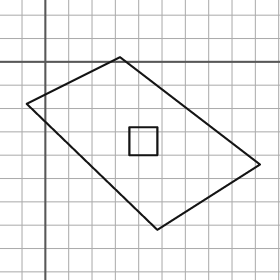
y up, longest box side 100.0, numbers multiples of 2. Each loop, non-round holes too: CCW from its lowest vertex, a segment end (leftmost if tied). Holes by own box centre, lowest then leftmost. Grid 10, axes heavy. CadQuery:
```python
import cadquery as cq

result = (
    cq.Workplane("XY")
    .moveTo(48.0, -72.0)
    .lineTo(92.0, -44.0)
    .lineTo(32.0, 2.0)
    .lineTo(-8.0, -18.0)
    .close()
    .moveTo(36.0, -40.0)
    .lineTo(48.0, -40.0)
    .lineTo(48.0, -28.0)
    .lineTo(36.0, -28.0)
    .close()
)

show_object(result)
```